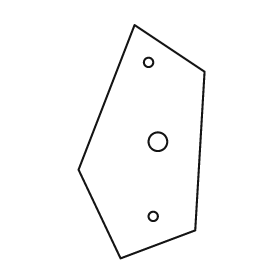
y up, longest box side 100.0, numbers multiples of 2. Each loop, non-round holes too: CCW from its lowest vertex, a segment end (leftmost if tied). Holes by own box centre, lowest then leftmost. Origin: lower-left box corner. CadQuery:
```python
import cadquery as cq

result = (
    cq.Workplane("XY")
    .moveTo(18.0, 0.0)
    .lineTo(50.0, 12.0)
    .lineTo(54.0, 80.0)
    .lineTo(24.0, 100.0)
    .lineTo(0.0, 38.0)
    .close()
    .moveTo(32.0, 18.0)
    .circle(2.0)
    .moveTo(34.0, 50.0)
    .circle(4.0)
    .moveTo(30.0, 84.0)
    .circle(2.0)
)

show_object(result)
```